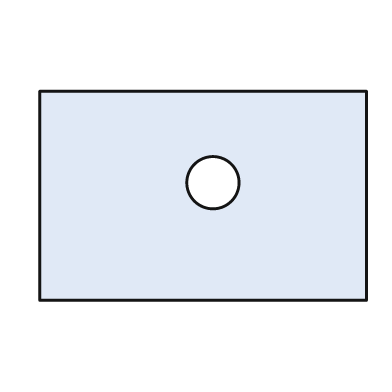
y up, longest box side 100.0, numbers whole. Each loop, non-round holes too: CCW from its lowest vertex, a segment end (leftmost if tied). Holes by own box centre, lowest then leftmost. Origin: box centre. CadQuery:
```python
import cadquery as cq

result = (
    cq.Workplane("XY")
    .moveTo(-50.0, -32.0)
    .lineTo(50.0, -32.0)
    .lineTo(50.0, 32.0)
    .lineTo(-50.0, 32.0)
    .close()
    .moveTo(3.0, 4.0)
    .circle(8.0)
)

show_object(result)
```